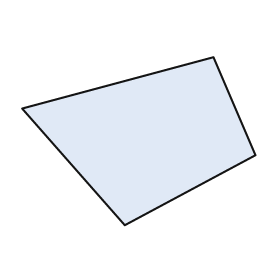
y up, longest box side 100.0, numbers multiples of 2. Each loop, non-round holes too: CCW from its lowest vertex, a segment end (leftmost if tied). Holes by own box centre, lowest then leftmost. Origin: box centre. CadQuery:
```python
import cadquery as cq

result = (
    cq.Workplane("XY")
    .moveTo(-6.0, -36.0)
    .lineTo(50.0, -6.0)
    .lineTo(32.0, 36.0)
    .lineTo(-50.0, 14.0)
    .close()
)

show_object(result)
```